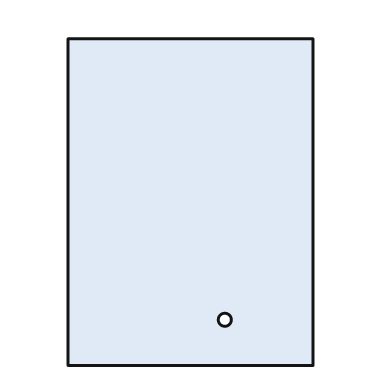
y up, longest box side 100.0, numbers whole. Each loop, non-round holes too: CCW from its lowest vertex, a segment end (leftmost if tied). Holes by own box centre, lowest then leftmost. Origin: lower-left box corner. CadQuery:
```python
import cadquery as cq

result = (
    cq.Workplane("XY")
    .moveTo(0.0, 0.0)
    .lineTo(75.0, 0.0)
    .lineTo(75.0, 100.0)
    .lineTo(0.0, 100.0)
    .close()
    .moveTo(48.0, 14.0)
    .circle(2.0)
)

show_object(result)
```